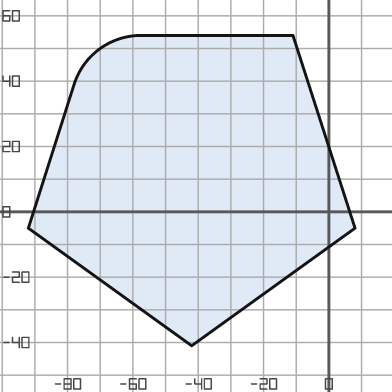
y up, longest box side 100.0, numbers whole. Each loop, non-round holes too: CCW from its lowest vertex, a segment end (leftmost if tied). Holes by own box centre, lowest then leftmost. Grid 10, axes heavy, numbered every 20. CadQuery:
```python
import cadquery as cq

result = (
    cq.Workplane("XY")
    .moveTo(-42.0, -41.0)
    .lineTo(8.0, -5.0)
    .lineTo(-11.0, 54.0)
    .lineTo(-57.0, 54.0)
    .threePointArc((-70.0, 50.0), (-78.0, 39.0))
    .lineTo(-92.0, -5.0)
    .close()
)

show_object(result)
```